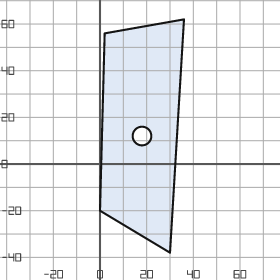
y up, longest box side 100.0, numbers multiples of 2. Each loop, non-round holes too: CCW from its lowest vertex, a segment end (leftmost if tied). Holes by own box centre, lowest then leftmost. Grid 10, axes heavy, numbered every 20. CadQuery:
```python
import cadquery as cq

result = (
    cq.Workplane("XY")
    .moveTo(30.0, -38.0)
    .lineTo(36.0, 62.0)
    .lineTo(2.0, 56.0)
    .lineTo(0.0, -20.0)
    .close()
    .moveTo(18.0, 12.0)
    .circle(4.0)
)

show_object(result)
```